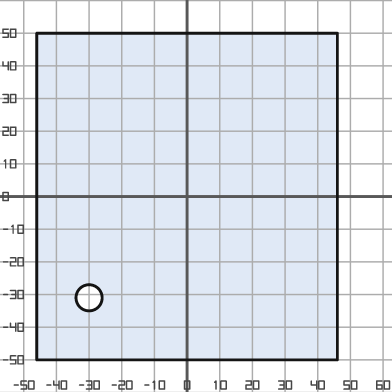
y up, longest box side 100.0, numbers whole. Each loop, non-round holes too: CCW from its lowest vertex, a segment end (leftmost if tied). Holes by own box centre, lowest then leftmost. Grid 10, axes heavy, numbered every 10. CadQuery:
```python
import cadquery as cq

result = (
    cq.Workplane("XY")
    .moveTo(-46.0, -50.0)
    .lineTo(46.0, -50.0)
    .lineTo(46.0, 50.0)
    .lineTo(-46.0, 50.0)
    .close()
    .moveTo(-30.0, -31.0)
    .circle(4.0)
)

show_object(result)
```